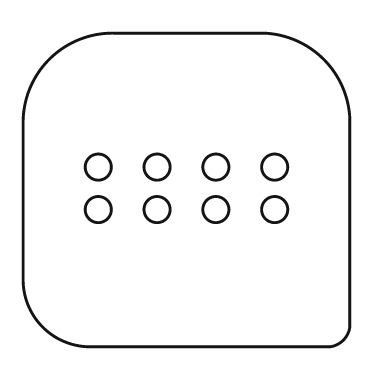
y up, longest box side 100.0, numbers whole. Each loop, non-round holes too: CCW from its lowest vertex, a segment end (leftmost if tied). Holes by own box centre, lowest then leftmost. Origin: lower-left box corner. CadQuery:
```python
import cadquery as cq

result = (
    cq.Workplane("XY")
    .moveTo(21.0, 0.0)
    .lineTo(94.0, 0.0)
    .threePointArc((98.0, 2.0), (100.0, 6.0))
    .lineTo(100.0, 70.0)
    .threePointArc((92.0, 88.0), (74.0, 96.0))
    .lineTo(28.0, 96.0)
    .threePointArc((8.0, 88.0), (0.0, 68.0))
    .lineTo(0.0, 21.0)
    .threePointArc((6.0, 6.0), (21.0, 0.0))
    .close()
    .moveTo(23.0, 42.0)
    .circle(4.0)
    .moveTo(41.0, 42.0)
    .circle(4.0)
    .moveTo(59.0, 42.0)
    .circle(4.0)
    .moveTo(77.0, 42.0)
    .circle(4.0)
    .moveTo(23.0, 55.0)
    .circle(4.0)
    .moveTo(41.0, 55.0)
    .circle(4.0)
    .moveTo(59.0, 55.0)
    .circle(4.0)
    .moveTo(77.0, 55.0)
    .circle(4.0)
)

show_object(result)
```